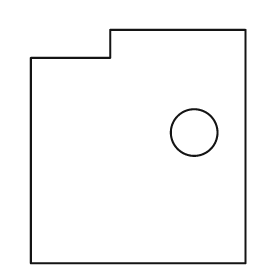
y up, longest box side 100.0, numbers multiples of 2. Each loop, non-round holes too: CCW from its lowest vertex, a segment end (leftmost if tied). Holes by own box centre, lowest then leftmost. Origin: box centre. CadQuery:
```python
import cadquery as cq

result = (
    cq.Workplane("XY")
    .moveTo(-46.0, -50.0)
    .lineTo(46.0, -50.0)
    .lineTo(46.0, 50.0)
    .lineTo(-12.0, 50.0)
    .lineTo(-12.0, 38.0)
    .lineTo(-46.0, 38.0)
    .close()
    .moveTo(24.0, 6.0)
    .circle(10.0)
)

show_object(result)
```